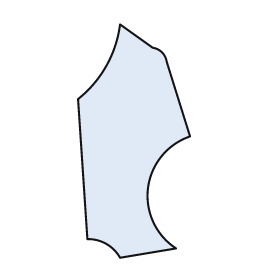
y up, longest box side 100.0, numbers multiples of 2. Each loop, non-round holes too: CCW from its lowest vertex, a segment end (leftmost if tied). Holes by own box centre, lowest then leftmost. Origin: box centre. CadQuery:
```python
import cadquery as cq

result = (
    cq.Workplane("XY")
    .moveTo(-6.0, -50.0)
    .lineTo(18.0, -46.0)
    .threePointArc((6.0, -20.0), (24.0, 2.0))
    .lineTo(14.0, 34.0)
    .threePointArc((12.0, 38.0), (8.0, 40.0))
    .lineTo(-6.0, 50.0)
    .threePointArc((-12.0, 32.0), (-24.0, 18.0))
    .lineTo(-20.0, -42.0)
    .threePointArc((-12.0, -44.0), (-6.0, -50.0))
    .close()
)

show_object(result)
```